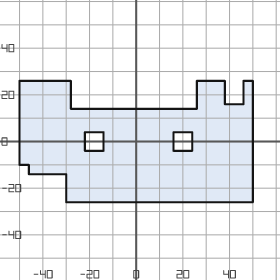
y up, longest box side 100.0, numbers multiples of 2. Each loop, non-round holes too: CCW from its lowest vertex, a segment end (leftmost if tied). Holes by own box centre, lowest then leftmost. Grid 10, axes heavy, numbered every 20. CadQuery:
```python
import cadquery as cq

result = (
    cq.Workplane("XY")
    .moveTo(-30.0, -26.0)
    .lineTo(50.0, -26.0)
    .lineTo(50.0, 26.0)
    .lineTo(46.0, 26.0)
    .lineTo(46.0, 16.0)
    .lineTo(38.0, 16.0)
    .lineTo(38.0, 26.0)
    .lineTo(26.0, 26.0)
    .lineTo(26.0, 14.0)
    .lineTo(-28.0, 14.0)
    .lineTo(-28.0, 26.0)
    .lineTo(-50.0, 26.0)
    .lineTo(-50.0, -10.0)
    .lineTo(-46.0, -10.0)
    .lineTo(-46.0, -14.0)
    .lineTo(-30.0, -14.0)
    .close()
    .moveTo(-22.0, -4.0)
    .lineTo(-14.0, -4.0)
    .lineTo(-14.0, 4.0)
    .lineTo(-22.0, 4.0)
    .close()
    .moveTo(16.0, -4.0)
    .lineTo(24.0, -4.0)
    .lineTo(24.0, 4.0)
    .lineTo(16.0, 4.0)
    .close()
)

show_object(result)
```